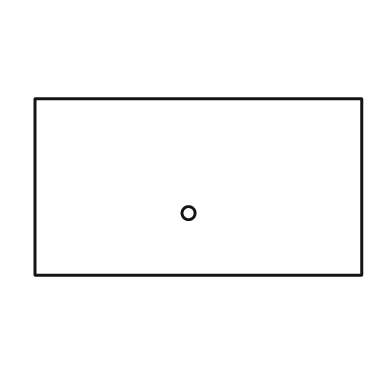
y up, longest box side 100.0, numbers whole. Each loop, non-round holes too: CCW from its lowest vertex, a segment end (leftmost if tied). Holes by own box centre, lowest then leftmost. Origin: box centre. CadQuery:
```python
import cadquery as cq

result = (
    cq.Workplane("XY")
    .moveTo(-50.0, -27.0)
    .lineTo(50.0, -27.0)
    .lineTo(50.0, 27.0)
    .lineTo(-50.0, 27.0)
    .close()
    .moveTo(-3.0, -8.0)
    .circle(2.0)
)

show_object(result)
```